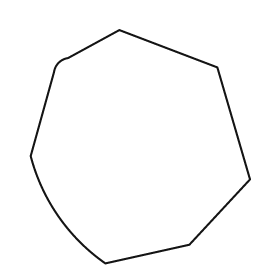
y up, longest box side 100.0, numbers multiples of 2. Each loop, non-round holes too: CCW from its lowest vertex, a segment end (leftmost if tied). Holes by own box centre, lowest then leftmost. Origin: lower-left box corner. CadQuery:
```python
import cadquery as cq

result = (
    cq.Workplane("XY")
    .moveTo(32.0, 0.0)
    .lineTo(68.0, 8.0)
    .lineTo(94.0, 36.0)
    .lineTo(80.0, 84.0)
    .lineTo(38.0, 100.0)
    .lineTo(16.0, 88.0)
    .threePointArc((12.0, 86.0), (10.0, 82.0))
    .lineTo(0.0, 46.0)
    .threePointArc((12.0, 20.0), (32.0, 0.0))
    .close()
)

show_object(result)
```